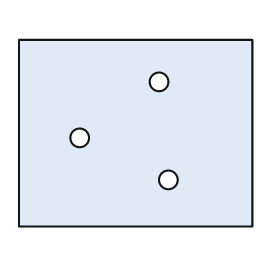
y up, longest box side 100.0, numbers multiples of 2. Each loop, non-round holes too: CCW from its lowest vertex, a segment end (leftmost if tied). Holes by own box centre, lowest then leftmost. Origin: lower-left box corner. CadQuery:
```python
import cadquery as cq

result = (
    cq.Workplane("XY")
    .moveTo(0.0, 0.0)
    .lineTo(100.0, 0.0)
    .lineTo(100.0, 80.0)
    .lineTo(0.0, 80.0)
    .close()
    .moveTo(64.0, 20.0)
    .circle(4.0)
    .moveTo(26.0, 38.0)
    .circle(4.0)
    .moveTo(60.0, 62.0)
    .circle(4.0)
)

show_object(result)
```